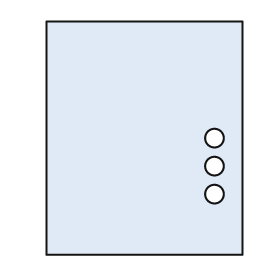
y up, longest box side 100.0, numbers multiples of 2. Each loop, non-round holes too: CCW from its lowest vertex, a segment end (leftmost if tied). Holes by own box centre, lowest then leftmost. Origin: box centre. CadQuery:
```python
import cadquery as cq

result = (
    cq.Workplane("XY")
    .moveTo(-42.0, -50.0)
    .lineTo(42.0, -50.0)
    .lineTo(42.0, 50.0)
    .lineTo(-42.0, 50.0)
    .close()
    .moveTo(30.0, -24.0)
    .circle(4.0)
    .moveTo(30.0, -12.0)
    .circle(4.0)
    .moveTo(30.0, 0.0)
    .circle(4.0)
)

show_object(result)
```